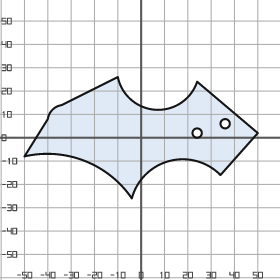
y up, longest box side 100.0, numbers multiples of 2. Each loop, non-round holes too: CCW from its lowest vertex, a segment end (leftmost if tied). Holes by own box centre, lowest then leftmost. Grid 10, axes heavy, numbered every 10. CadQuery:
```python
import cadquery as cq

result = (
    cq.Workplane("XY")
    .moveTo(-4.0, -26.0)
    .threePointArc((12.0, -10.0), (34.0, -16.0))
    .lineTo(50.0, 2.0)
    .lineTo(24.0, 24.0)
    .threePointArc((6.0, 12.0), (-10.0, 26.0))
    .lineTo(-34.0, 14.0)
    .threePointArc((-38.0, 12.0), (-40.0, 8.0))
    .lineTo(-50.0, -8.0)
    .threePointArc((-24.0, -10.0), (-4.0, -26.0))
    .close()
    .moveTo(24.0, 2.0)
    .circle(2.0)
    .moveTo(36.0, 6.0)
    .circle(2.0)
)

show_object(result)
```